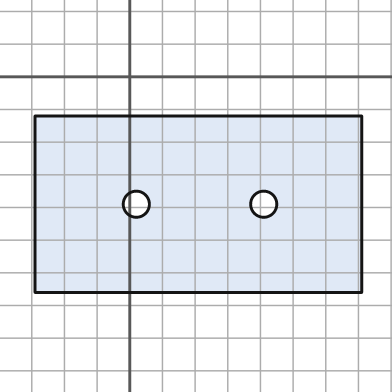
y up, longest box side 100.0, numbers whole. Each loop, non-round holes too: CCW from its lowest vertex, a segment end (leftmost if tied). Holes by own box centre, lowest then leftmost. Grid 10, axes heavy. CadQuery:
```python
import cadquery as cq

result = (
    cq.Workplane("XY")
    .moveTo(-29.0, -66.0)
    .lineTo(71.0, -66.0)
    .lineTo(71.0, -12.0)
    .lineTo(-29.0, -12.0)
    .close()
    .moveTo(2.0, -39.0)
    .circle(4.0)
    .moveTo(41.0, -39.0)
    .circle(4.0)
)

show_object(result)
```